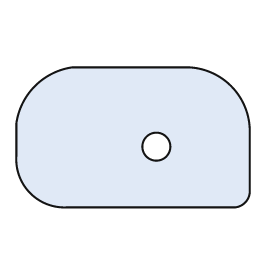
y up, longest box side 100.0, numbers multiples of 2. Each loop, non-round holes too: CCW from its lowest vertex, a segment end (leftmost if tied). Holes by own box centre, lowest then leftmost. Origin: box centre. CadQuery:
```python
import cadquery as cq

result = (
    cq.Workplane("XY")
    .moveTo(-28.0, -30.0)
    .lineTo(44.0, -30.0)
    .threePointArc((48.0, -28.0), (50.0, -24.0))
    .lineTo(50.0, 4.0)
    .threePointArc((42.0, 22.0), (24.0, 30.0))
    .lineTo(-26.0, 30.0)
    .threePointArc((-42.0, 22.0), (-50.0, 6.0))
    .lineTo(-50.0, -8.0)
    .threePointArc((-44.0, -24.0), (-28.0, -30.0))
    .close()
    .moveTo(10.0, -4.0)
    .circle(6.0)
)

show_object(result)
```